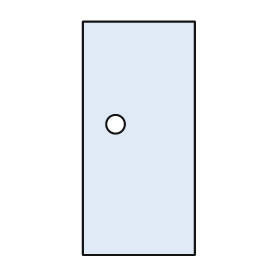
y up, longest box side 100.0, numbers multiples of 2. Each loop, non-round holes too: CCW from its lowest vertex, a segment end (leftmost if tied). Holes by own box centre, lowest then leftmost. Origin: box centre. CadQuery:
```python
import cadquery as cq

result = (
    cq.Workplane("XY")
    .moveTo(-24.0, -50.0)
    .lineTo(24.0, -50.0)
    .lineTo(24.0, 50.0)
    .lineTo(-24.0, 50.0)
    .close()
    .moveTo(-10.0, 6.0)
    .circle(4.0)
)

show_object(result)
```